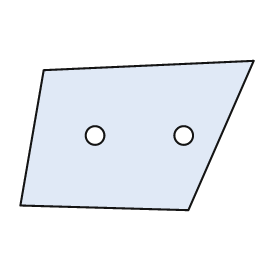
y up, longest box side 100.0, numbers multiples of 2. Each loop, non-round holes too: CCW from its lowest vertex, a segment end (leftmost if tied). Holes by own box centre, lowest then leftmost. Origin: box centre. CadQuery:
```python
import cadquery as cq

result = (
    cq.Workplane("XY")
    .moveTo(22.0, -32.0)
    .lineTo(50.0, 32.0)
    .lineTo(-40.0, 28.0)
    .lineTo(-50.0, -30.0)
    .close()
    .moveTo(-18.0, 0.0)
    .circle(4.0)
    .moveTo(20.0, 0.0)
    .circle(4.0)
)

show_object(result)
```